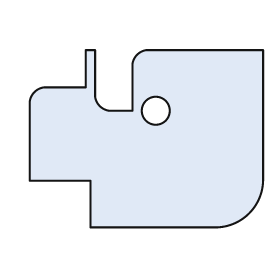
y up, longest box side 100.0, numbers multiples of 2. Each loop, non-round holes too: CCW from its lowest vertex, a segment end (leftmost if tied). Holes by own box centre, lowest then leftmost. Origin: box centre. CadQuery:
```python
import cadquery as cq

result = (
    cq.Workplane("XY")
    .moveTo(-24.0, -38.0)
    .lineTo(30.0, -38.0)
    .threePointArc((44.0, -32.0), (50.0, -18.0))
    .lineTo(50.0, 38.0)
    .lineTo(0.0, 38.0)
    .threePointArc((-4.0, 36.0), (-6.0, 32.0))
    .lineTo(-6.0, 12.0)
    .lineTo(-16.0, 12.0)
    .threePointArc((-20.0, 14.0), (-22.0, 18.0))
    .lineTo(-22.0, 38.0)
    .lineTo(-26.0, 38.0)
    .lineTo(-26.0, 22.0)
    .lineTo(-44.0, 22.0)
    .threePointArc((-48.0, 20.0), (-50.0, 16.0))
    .lineTo(-50.0, -18.0)
    .lineTo(-24.0, -18.0)
    .close()
    .moveTo(4.0, 12.0)
    .circle(6.0)
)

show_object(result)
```